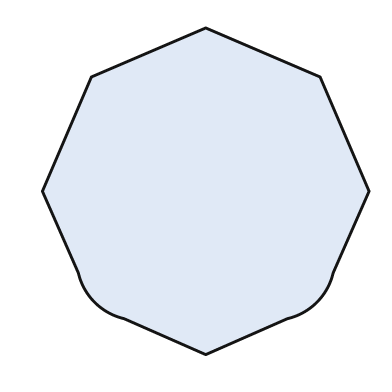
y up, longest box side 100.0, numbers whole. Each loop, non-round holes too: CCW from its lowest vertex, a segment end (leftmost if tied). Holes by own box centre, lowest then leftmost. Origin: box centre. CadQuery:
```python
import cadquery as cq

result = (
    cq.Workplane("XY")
    .moveTo(0.0, -50.0)
    .lineTo(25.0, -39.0)
    .threePointArc((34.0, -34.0), (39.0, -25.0))
    .lineTo(50.0, 0.0)
    .lineTo(35.0, 35.0)
    .lineTo(0.0, 50.0)
    .lineTo(-35.0, 35.0)
    .lineTo(-50.0, 0.0)
    .lineTo(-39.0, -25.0)
    .threePointArc((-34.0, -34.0), (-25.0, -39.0))
    .close()
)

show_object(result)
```